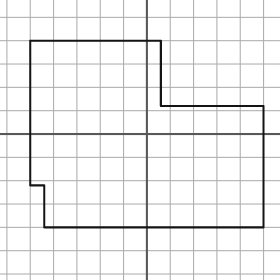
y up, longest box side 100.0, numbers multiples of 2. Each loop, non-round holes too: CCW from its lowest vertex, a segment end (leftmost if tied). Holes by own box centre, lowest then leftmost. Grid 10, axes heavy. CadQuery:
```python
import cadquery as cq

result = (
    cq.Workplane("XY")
    .moveTo(-44.0, -40.0)
    .lineTo(50.0, -40.0)
    .lineTo(50.0, 12.0)
    .lineTo(6.0, 12.0)
    .lineTo(6.0, 40.0)
    .lineTo(-50.0, 40.0)
    .lineTo(-50.0, -22.0)
    .lineTo(-44.0, -22.0)
    .close()
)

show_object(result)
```